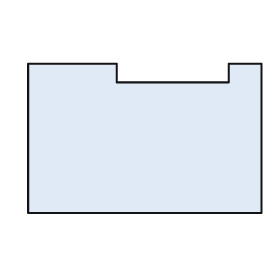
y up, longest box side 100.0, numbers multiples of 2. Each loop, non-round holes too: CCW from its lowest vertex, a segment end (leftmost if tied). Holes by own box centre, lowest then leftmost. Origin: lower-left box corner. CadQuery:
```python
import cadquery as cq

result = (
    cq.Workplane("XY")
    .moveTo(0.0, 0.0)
    .lineTo(100.0, 0.0)
    .lineTo(100.0, 64.0)
    .lineTo(86.0, 64.0)
    .lineTo(86.0, 56.0)
    .lineTo(38.0, 56.0)
    .lineTo(38.0, 64.0)
    .lineTo(0.0, 64.0)
    .close()
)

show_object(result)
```